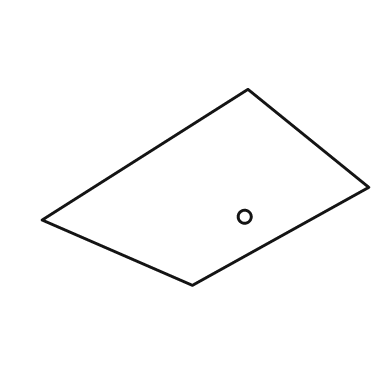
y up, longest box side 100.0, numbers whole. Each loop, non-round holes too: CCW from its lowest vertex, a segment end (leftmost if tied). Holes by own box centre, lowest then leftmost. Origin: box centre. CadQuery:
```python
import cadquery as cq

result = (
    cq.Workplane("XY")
    .moveTo(-4.0, -30.0)
    .lineTo(50.0, 0.0)
    .lineTo(13.0, 30.0)
    .lineTo(-50.0, -10.0)
    .close()
    .moveTo(12.0, -9.0)
    .circle(2.0)
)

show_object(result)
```